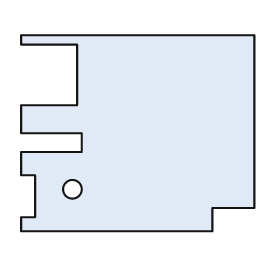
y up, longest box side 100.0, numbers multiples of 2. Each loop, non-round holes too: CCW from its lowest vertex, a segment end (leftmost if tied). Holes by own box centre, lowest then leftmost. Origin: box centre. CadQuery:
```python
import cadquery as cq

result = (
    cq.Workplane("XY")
    .moveTo(-50.0, -42.0)
    .lineTo(32.0, -42.0)
    .lineTo(32.0, -32.0)
    .lineTo(50.0, -32.0)
    .lineTo(50.0, 42.0)
    .lineTo(-50.0, 42.0)
    .lineTo(-50.0, 38.0)
    .lineTo(-26.0, 38.0)
    .lineTo(-26.0, 12.0)
    .lineTo(-50.0, 12.0)
    .lineTo(-50.0, 0.0)
    .lineTo(-24.0, 0.0)
    .lineTo(-24.0, -8.0)
    .lineTo(-50.0, -8.0)
    .lineTo(-50.0, -18.0)
    .lineTo(-44.0, -18.0)
    .lineTo(-44.0, -36.0)
    .lineTo(-50.0, -36.0)
    .close()
    .moveTo(-28.0, -24.0)
    .circle(4.0)
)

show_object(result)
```